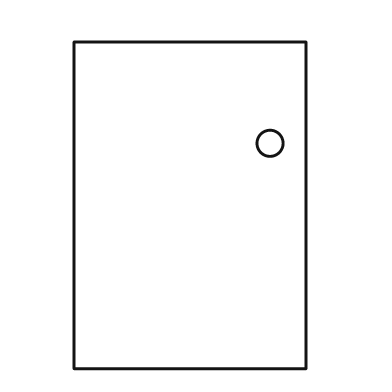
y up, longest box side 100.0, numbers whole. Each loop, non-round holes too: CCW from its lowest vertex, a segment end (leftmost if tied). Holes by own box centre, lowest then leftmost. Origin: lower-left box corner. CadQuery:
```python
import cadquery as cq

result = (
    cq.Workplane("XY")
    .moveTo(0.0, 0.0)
    .lineTo(71.0, 0.0)
    .lineTo(71.0, 100.0)
    .lineTo(0.0, 100.0)
    .close()
    .moveTo(60.0, 69.0)
    .circle(4.0)
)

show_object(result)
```